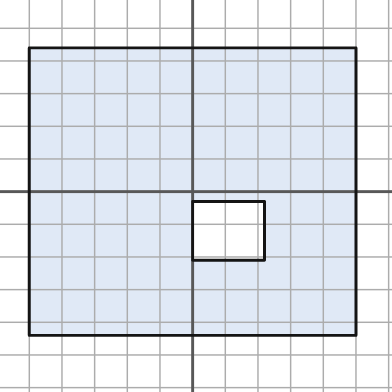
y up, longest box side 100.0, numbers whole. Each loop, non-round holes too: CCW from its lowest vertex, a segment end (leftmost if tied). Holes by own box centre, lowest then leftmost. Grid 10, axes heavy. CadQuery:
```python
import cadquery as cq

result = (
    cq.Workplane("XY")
    .moveTo(-50.0, -44.0)
    .lineTo(50.0, -44.0)
    .lineTo(50.0, 44.0)
    .lineTo(-50.0, 44.0)
    .close()
    .moveTo(0.0, -21.0)
    .lineTo(22.0, -21.0)
    .lineTo(22.0, -3.0)
    .lineTo(0.0, -3.0)
    .close()
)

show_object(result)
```